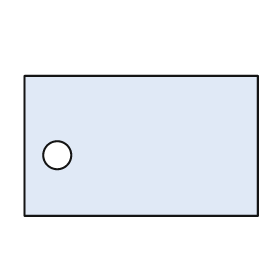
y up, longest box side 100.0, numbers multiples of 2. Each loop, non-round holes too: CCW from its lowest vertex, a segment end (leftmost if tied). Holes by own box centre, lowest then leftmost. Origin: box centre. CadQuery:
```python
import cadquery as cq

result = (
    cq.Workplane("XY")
    .moveTo(-50.0, -30.0)
    .lineTo(50.0, -30.0)
    .lineTo(50.0, 30.0)
    .lineTo(-50.0, 30.0)
    .close()
    .moveTo(-36.0, -4.0)
    .circle(6.0)
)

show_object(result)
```